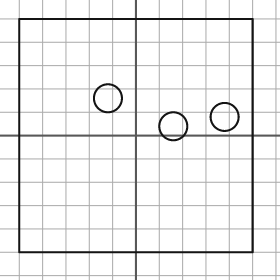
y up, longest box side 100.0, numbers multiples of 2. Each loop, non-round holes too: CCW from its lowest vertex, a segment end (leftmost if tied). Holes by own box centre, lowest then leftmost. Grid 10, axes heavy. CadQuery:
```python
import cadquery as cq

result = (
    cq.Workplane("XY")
    .moveTo(-50.0, -50.0)
    .lineTo(50.0, -50.0)
    .lineTo(50.0, 50.0)
    .lineTo(-50.0, 50.0)
    .close()
    .moveTo(16.0, 4.0)
    .circle(6.0)
    .moveTo(38.0, 8.0)
    .circle(6.0)
    .moveTo(-12.0, 16.0)
    .circle(6.0)
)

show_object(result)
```